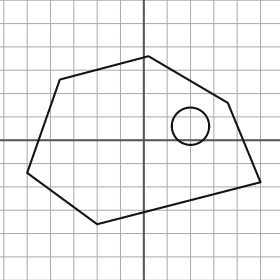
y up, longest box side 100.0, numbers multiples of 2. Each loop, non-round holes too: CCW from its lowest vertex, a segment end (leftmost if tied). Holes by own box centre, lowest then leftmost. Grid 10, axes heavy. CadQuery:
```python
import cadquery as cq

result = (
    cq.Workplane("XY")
    .moveTo(-20.0, -36.0)
    .lineTo(50.0, -18.0)
    .lineTo(36.0, 16.0)
    .lineTo(2.0, 36.0)
    .lineTo(-36.0, 26.0)
    .lineTo(-50.0, -14.0)
    .close()
    .moveTo(20.0, 6.0)
    .circle(8.0)
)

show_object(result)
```